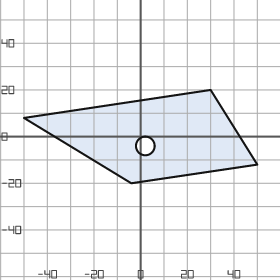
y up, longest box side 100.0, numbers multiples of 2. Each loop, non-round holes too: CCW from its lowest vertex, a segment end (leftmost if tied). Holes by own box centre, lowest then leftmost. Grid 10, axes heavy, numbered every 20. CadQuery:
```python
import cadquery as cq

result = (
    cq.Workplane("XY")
    .moveTo(-4.0, -20.0)
    .lineTo(50.0, -12.0)
    .lineTo(30.0, 20.0)
    .lineTo(-50.0, 8.0)
    .close()
    .moveTo(2.0, -4.0)
    .circle(4.0)
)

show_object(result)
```